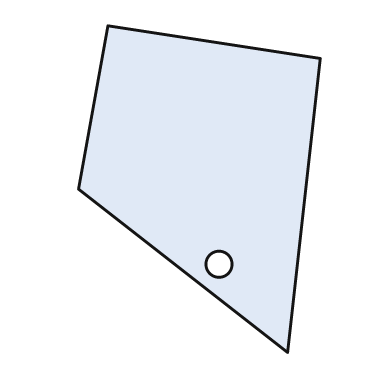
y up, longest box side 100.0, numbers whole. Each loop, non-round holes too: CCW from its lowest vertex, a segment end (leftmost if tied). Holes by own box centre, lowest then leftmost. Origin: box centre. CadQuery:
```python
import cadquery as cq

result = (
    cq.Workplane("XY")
    .moveTo(27.0, -50.0)
    .lineTo(37.0, 40.0)
    .lineTo(-28.0, 50.0)
    .lineTo(-37.0, 0.0)
    .close()
    .moveTo(6.0, -23.0)
    .circle(4.0)
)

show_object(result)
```